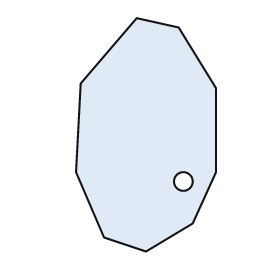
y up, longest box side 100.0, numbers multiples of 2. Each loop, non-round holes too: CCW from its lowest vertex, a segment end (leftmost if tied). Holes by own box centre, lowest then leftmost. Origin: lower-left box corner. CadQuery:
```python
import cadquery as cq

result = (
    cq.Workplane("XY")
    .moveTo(30.0, 0.0)
    .lineTo(50.0, 12.0)
    .lineTo(60.0, 34.0)
    .lineTo(60.0, 70.0)
    .lineTo(44.0, 96.0)
    .lineTo(26.0, 100.0)
    .lineTo(2.0, 72.0)
    .lineTo(0.0, 34.0)
    .lineTo(12.0, 6.0)
    .close()
    .moveTo(46.0, 30.0)
    .circle(4.0)
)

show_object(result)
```